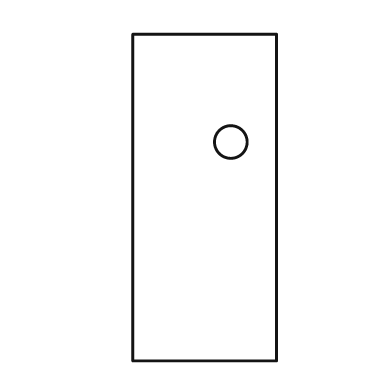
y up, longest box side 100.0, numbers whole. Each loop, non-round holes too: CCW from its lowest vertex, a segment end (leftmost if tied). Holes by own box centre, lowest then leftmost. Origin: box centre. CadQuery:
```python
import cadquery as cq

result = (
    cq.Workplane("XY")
    .moveTo(-22.0, -50.0)
    .lineTo(22.0, -50.0)
    .lineTo(22.0, 50.0)
    .lineTo(-22.0, 50.0)
    .close()
    .moveTo(8.0, 17.0)
    .circle(5.0)
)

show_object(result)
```